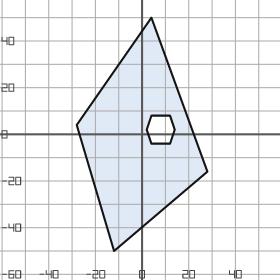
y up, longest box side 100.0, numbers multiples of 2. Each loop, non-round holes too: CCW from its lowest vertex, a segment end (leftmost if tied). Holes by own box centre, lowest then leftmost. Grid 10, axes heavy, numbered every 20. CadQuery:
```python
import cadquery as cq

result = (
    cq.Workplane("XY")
    .moveTo(-12.0, -50.0)
    .lineTo(28.0, -16.0)
    .lineTo(4.0, 50.0)
    .lineTo(-28.0, 4.0)
    .close()
    .moveTo(4.0, -4.0)
    .lineTo(12.0, -4.0)
    .lineTo(14.0, 2.0)
    .lineTo(12.0, 8.0)
    .lineTo(4.0, 8.0)
    .lineTo(2.0, 2.0)
    .close()
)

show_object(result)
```